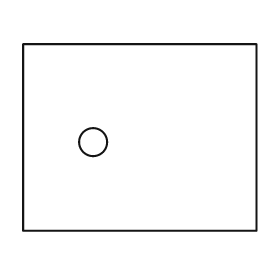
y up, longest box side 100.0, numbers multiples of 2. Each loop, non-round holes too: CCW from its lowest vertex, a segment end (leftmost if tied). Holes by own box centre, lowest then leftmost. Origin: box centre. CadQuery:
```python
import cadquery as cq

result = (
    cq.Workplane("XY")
    .moveTo(-50.0, -40.0)
    .lineTo(50.0, -40.0)
    .lineTo(50.0, 40.0)
    .lineTo(-50.0, 40.0)
    .close()
    .moveTo(-20.0, -2.0)
    .circle(6.0)
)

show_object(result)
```